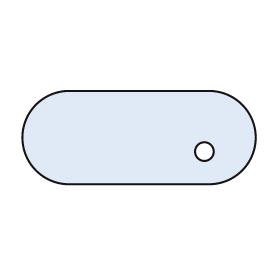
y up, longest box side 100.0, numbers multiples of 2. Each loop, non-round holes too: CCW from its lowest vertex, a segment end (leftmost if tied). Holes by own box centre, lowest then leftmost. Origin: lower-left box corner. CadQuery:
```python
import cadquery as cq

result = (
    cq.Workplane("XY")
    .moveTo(20.0, 0.0)
    .lineTo(80.0, 0.0)
    .threePointArc((100.0, 20.0), (80.0, 40.0))
    .lineTo(20.0, 40.0)
    .threePointArc((0.0, 20.0), (20.0, 0.0))
    .close()
    .moveTo(78.0, 14.0)
    .circle(4.0)
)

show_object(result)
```